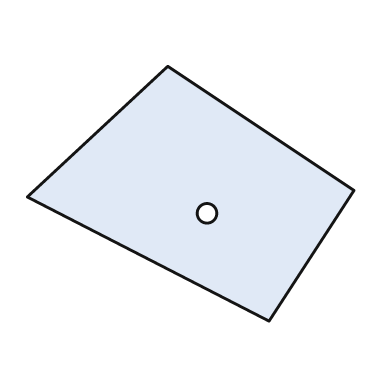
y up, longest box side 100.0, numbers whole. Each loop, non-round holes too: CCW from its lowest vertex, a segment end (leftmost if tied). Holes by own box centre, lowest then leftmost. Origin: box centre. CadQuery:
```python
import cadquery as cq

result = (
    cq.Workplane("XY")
    .moveTo(24.0, -39.0)
    .lineTo(50.0, 1.0)
    .lineTo(-7.0, 39.0)
    .lineTo(-50.0, -1.0)
    .close()
    .moveTo(5.0, -6.0)
    .circle(3.0)
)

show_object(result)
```